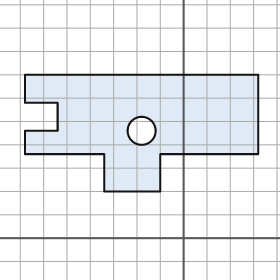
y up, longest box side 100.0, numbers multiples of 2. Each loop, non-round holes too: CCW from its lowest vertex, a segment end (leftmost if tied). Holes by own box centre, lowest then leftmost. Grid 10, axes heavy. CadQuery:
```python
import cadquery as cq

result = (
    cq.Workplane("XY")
    .moveTo(-34.0, 20.0)
    .lineTo(-10.0, 20.0)
    .lineTo(-10.0, 36.0)
    .lineTo(32.0, 36.0)
    .lineTo(32.0, 70.0)
    .lineTo(-68.0, 70.0)
    .lineTo(-68.0, 58.0)
    .lineTo(-54.0, 58.0)
    .lineTo(-54.0, 46.0)
    .lineTo(-68.0, 46.0)
    .lineTo(-68.0, 36.0)
    .lineTo(-34.0, 36.0)
    .close()
    .moveTo(-18.0, 46.0)
    .circle(6.0)
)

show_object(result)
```